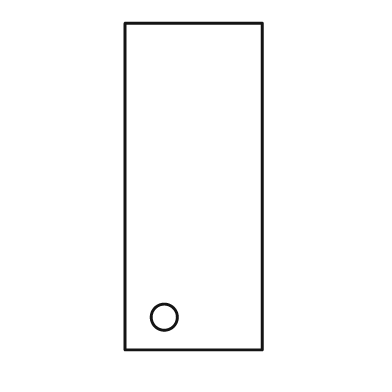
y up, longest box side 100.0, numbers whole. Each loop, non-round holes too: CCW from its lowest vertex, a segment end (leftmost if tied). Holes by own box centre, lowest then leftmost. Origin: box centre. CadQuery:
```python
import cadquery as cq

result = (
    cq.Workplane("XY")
    .moveTo(-21.0, -50.0)
    .lineTo(21.0, -50.0)
    .lineTo(21.0, 50.0)
    .lineTo(-21.0, 50.0)
    .close()
    .moveTo(-9.0, -40.0)
    .circle(4.0)
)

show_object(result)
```